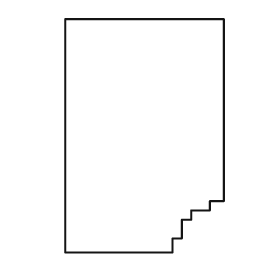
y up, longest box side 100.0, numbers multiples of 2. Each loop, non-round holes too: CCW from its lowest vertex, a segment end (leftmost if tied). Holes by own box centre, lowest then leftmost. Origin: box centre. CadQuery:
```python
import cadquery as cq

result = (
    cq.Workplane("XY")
    .moveTo(-34.0, -50.0)
    .lineTo(12.0, -50.0)
    .lineTo(12.0, -44.0)
    .lineTo(16.0, -44.0)
    .lineTo(16.0, -36.0)
    .lineTo(20.0, -36.0)
    .lineTo(20.0, -32.0)
    .lineTo(28.0, -32.0)
    .lineTo(28.0, -28.0)
    .lineTo(34.0, -28.0)
    .lineTo(34.0, 50.0)
    .lineTo(-34.0, 50.0)
    .close()
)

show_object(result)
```